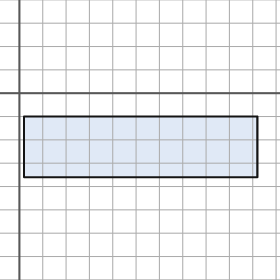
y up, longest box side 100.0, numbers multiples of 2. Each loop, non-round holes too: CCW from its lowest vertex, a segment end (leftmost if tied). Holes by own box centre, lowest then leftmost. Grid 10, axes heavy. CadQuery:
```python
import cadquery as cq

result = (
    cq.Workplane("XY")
    .moveTo(2.0, -36.0)
    .lineTo(102.0, -36.0)
    .lineTo(102.0, -10.0)
    .lineTo(2.0, -10.0)
    .close()
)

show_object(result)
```